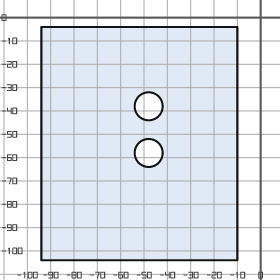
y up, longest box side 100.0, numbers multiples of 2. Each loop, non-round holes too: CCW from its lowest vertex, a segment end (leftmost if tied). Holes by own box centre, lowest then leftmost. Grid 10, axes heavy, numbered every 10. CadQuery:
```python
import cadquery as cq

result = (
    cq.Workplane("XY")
    .moveTo(-94.0, -104.0)
    .lineTo(-10.0, -104.0)
    .lineTo(-10.0, -4.0)
    .lineTo(-94.0, -4.0)
    .close()
    .moveTo(-48.0, -58.0)
    .circle(6.0)
    .moveTo(-48.0, -38.0)
    .circle(6.0)
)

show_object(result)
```